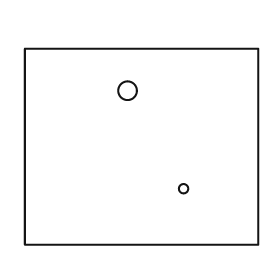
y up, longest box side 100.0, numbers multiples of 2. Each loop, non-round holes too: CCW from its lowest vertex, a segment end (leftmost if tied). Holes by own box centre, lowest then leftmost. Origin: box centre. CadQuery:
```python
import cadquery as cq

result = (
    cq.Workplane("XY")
    .moveTo(-50.0, -42.0)
    .lineTo(50.0, -42.0)
    .lineTo(50.0, 42.0)
    .lineTo(-50.0, 42.0)
    .close()
    .moveTo(18.0, -18.0)
    .circle(2.0)
    .moveTo(-6.0, 24.0)
    .circle(4.0)
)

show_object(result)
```